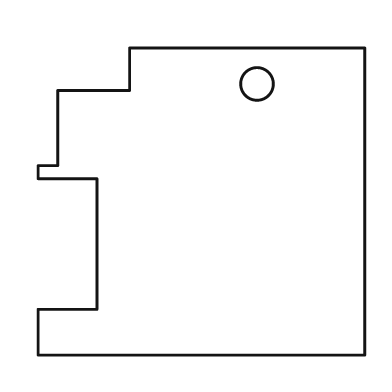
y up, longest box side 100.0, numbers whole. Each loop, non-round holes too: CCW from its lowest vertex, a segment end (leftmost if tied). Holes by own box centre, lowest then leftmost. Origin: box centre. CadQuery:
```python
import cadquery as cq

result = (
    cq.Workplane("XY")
    .moveTo(-50.0, -47.0)
    .lineTo(50.0, -47.0)
    .lineTo(50.0, 47.0)
    .lineTo(-22.0, 47.0)
    .lineTo(-22.0, 34.0)
    .lineTo(-44.0, 34.0)
    .lineTo(-44.0, 11.0)
    .lineTo(-50.0, 11.0)
    .lineTo(-50.0, 7.0)
    .lineTo(-32.0, 7.0)
    .lineTo(-32.0, -33.0)
    .lineTo(-50.0, -33.0)
    .close()
    .moveTo(17.0, 36.0)
    .circle(5.0)
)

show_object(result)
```